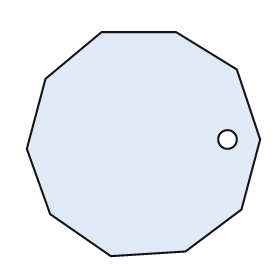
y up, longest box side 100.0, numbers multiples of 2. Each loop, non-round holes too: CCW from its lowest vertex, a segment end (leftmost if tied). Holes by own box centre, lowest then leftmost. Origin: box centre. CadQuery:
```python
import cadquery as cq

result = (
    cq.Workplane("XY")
    .moveTo(-14.0, -48.0)
    .lineTo(18.0, -46.0)
    .lineTo(42.0, -28.0)
    .lineTo(50.0, 2.0)
    .lineTo(40.0, 32.0)
    .lineTo(14.0, 48.0)
    .lineTo(-18.0, 48.0)
    .lineTo(-42.0, 28.0)
    .lineTo(-50.0, -2.0)
    .lineTo(-40.0, -30.0)
    .close()
    .moveTo(36.0, 2.0)
    .circle(4.0)
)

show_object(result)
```